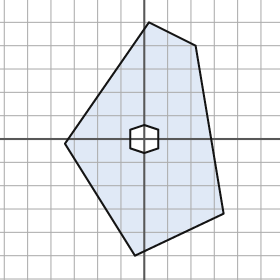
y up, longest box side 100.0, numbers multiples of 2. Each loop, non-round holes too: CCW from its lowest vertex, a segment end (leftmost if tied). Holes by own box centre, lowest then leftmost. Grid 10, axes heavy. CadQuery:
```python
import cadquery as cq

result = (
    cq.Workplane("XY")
    .moveTo(-4.0, -50.0)
    .lineTo(34.0, -32.0)
    .lineTo(22.0, 40.0)
    .lineTo(2.0, 50.0)
    .lineTo(-34.0, -2.0)
    .close()
    .moveTo(0.0, -6.0)
    .lineTo(6.0, -4.0)
    .lineTo(6.0, 4.0)
    .lineTo(0.0, 6.0)
    .lineTo(-6.0, 4.0)
    .lineTo(-6.0, -4.0)
    .close()
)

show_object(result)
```